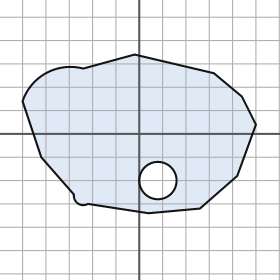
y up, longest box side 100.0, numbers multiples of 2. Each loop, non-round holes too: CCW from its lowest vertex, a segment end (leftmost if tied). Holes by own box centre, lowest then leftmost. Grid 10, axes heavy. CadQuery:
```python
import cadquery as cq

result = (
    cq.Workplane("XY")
    .moveTo(4.0, -34.0)
    .lineTo(26.0, -32.0)
    .lineTo(42.0, -18.0)
    .lineTo(50.0, 4.0)
    .lineTo(44.0, 16.0)
    .lineTo(32.0, 26.0)
    .lineTo(-2.0, 34.0)
    .lineTo(-24.0, 28.0)
    .threePointArc((-40.0, 26.0), (-50.0, 14.0))
    .lineTo(-42.0, -10.0)
    .lineTo(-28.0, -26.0)
    .threePointArc((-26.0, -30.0), (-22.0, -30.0))
    .close()
    .moveTo(8.0, -20.0)
    .circle(8.0)
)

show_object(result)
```